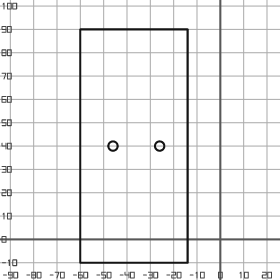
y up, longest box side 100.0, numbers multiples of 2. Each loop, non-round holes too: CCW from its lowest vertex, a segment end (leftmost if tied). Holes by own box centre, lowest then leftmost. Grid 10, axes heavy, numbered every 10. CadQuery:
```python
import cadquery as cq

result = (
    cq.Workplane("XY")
    .moveTo(-60.0, -10.0)
    .lineTo(-14.0, -10.0)
    .lineTo(-14.0, 90.0)
    .lineTo(-60.0, 90.0)
    .close()
    .moveTo(-46.0, 40.0)
    .circle(2.0)
    .moveTo(-26.0, 40.0)
    .circle(2.0)
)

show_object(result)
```